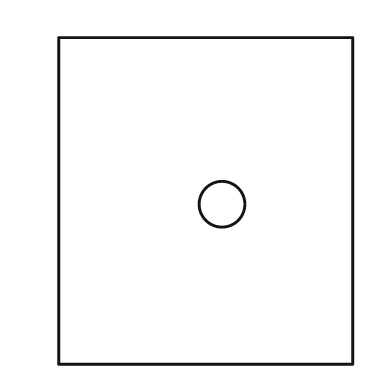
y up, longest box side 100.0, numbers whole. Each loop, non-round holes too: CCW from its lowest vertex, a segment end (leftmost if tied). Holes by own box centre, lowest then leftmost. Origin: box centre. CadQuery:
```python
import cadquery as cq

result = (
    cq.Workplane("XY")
    .moveTo(-45.0, -50.0)
    .lineTo(45.0, -50.0)
    .lineTo(45.0, 50.0)
    .lineTo(-45.0, 50.0)
    .close()
    .moveTo(5.0, -1.0)
    .circle(7.0)
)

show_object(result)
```